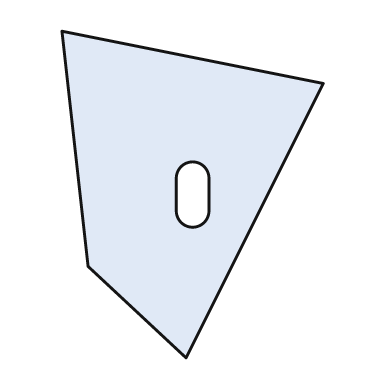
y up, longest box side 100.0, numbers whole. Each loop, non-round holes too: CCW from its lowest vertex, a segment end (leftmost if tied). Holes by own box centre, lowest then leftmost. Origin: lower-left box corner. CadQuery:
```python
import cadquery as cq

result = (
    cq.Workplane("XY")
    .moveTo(38.0, 0.0)
    .lineTo(80.0, 84.0)
    .lineTo(0.0, 100.0)
    .lineTo(8.0, 28.0)
    .close()
    .moveTo(35.0, 45.0)
    .threePointArc((40.0, 40.0), (45.0, 45.0))
    .lineTo(45.0, 55.0)
    .threePointArc((40.0, 60.0), (35.0, 55.0))
    .close()
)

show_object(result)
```